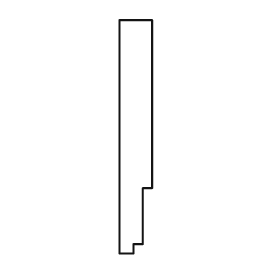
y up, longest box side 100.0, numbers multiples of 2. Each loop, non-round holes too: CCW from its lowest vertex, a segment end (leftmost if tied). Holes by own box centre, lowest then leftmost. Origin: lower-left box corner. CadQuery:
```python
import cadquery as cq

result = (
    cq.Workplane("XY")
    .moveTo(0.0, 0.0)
    .lineTo(6.0, 0.0)
    .lineTo(6.0, 4.0)
    .lineTo(10.0, 4.0)
    .lineTo(10.0, 28.0)
    .lineTo(14.0, 28.0)
    .lineTo(14.0, 100.0)
    .lineTo(0.0, 100.0)
    .close()
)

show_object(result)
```